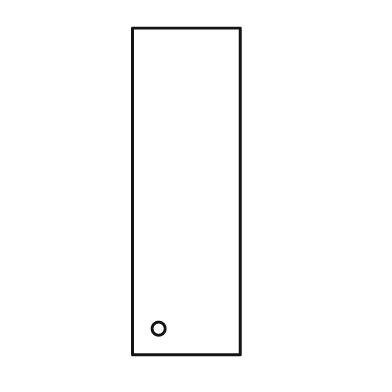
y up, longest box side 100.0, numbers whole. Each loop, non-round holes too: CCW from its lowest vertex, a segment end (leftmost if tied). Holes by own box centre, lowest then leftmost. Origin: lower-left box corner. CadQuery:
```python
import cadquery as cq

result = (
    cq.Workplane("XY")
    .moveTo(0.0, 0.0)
    .lineTo(33.0, 0.0)
    .lineTo(33.0, 100.0)
    .lineTo(0.0, 100.0)
    .close()
    .moveTo(8.0, 8.0)
    .circle(2.0)
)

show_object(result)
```